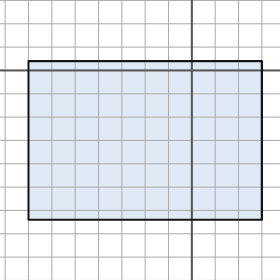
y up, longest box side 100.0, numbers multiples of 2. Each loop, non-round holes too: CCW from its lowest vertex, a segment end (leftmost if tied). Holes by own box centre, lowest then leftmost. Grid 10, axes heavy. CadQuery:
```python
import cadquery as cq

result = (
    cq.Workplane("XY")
    .moveTo(-70.0, -64.0)
    .lineTo(30.0, -64.0)
    .lineTo(30.0, 4.0)
    .lineTo(-70.0, 4.0)
    .close()
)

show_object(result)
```